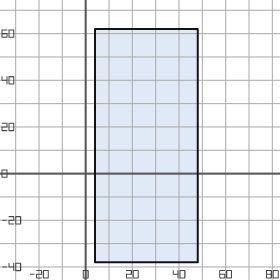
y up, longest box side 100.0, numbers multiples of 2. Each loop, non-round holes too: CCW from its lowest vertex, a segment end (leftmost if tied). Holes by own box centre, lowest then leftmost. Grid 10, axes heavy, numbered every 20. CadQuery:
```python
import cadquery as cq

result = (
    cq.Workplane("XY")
    .moveTo(4.0, -38.0)
    .lineTo(48.0, -38.0)
    .lineTo(48.0, 62.0)
    .lineTo(4.0, 62.0)
    .close()
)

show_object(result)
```